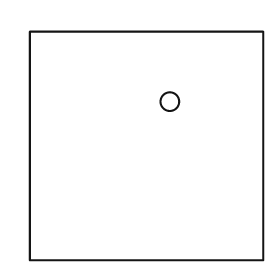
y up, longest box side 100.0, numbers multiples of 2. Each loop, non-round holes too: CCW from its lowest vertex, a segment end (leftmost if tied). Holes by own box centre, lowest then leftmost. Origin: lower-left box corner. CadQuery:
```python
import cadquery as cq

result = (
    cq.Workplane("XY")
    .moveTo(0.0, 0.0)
    .lineTo(100.0, 0.0)
    .lineTo(100.0, 98.0)
    .lineTo(0.0, 98.0)
    .close()
    .moveTo(60.0, 68.0)
    .circle(4.0)
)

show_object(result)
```